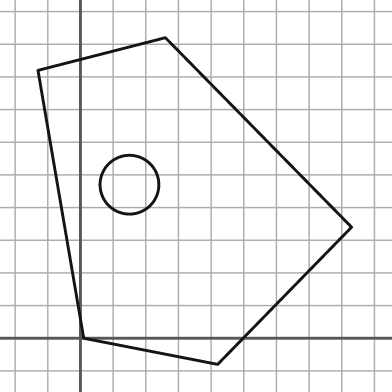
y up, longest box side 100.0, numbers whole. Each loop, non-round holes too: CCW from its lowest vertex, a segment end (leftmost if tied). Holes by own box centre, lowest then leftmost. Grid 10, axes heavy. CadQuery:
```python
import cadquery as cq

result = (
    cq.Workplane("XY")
    .moveTo(42.0, -8.0)
    .lineTo(83.0, 34.0)
    .lineTo(26.0, 92.0)
    .lineTo(-13.0, 82.0)
    .lineTo(1.0, 0.0)
    .close()
    .moveTo(15.0, 47.0)
    .circle(9.0)
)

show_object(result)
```